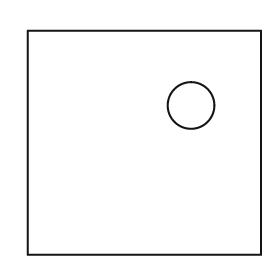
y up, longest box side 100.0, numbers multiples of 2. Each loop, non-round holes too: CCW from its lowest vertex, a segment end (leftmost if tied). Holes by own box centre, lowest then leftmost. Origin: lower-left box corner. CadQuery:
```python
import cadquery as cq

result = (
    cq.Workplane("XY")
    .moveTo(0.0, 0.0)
    .lineTo(100.0, 0.0)
    .lineTo(100.0, 96.0)
    .lineTo(0.0, 96.0)
    .close()
    .moveTo(70.0, 64.0)
    .circle(10.0)
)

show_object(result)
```